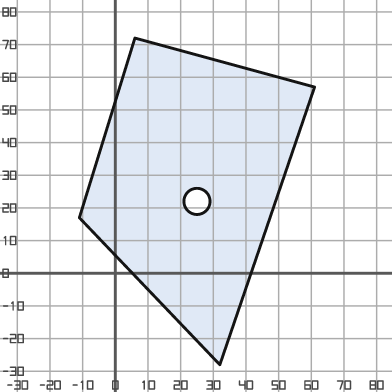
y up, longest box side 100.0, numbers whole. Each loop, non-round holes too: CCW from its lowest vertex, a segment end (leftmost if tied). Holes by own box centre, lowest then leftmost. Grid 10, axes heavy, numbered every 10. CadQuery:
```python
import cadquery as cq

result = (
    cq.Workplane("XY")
    .moveTo(32.0, -28.0)
    .lineTo(61.0, 57.0)
    .lineTo(6.0, 72.0)
    .lineTo(-11.0, 17.0)
    .close()
    .moveTo(25.0, 22.0)
    .circle(4.0)
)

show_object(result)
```